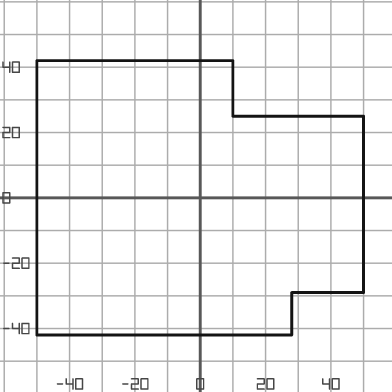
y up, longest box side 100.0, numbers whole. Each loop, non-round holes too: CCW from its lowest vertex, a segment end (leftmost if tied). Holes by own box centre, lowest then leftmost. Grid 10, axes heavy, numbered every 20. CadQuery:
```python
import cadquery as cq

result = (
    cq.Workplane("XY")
    .moveTo(-50.0, -42.0)
    .lineTo(28.0, -42.0)
    .lineTo(28.0, -29.0)
    .lineTo(50.0, -29.0)
    .lineTo(50.0, 25.0)
    .lineTo(10.0, 25.0)
    .lineTo(10.0, 42.0)
    .lineTo(-50.0, 42.0)
    .close()
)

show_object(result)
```